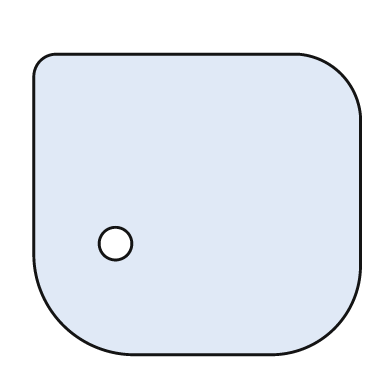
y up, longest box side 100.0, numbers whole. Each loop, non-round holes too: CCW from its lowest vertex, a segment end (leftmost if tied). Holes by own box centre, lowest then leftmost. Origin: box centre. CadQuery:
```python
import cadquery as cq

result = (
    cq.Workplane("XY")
    .moveTo(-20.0, -46.0)
    .lineTo(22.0, -46.0)
    .threePointArc((42.0, -38.0), (50.0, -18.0))
    .lineTo(50.0, 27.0)
    .threePointArc((44.0, 40.0), (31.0, 46.0))
    .lineTo(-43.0, 46.0)
    .threePointArc((-48.0, 44.0), (-50.0, 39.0))
    .lineTo(-50.0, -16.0)
    .threePointArc((-41.0, -37.0), (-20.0, -46.0))
    .close()
    .moveTo(-25.0, -12.0)
    .circle(5.0)
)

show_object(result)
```